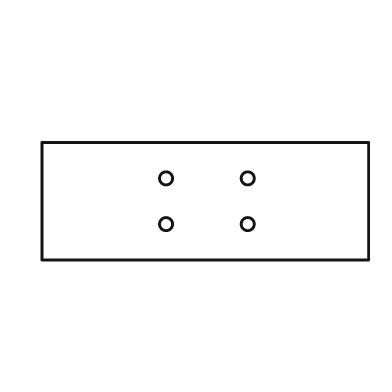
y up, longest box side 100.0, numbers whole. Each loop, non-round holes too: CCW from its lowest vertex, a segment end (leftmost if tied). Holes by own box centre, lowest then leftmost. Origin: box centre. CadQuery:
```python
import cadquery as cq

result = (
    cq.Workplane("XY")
    .moveTo(-50.0, -18.0)
    .lineTo(50.0, -18.0)
    .lineTo(50.0, 18.0)
    .lineTo(-50.0, 18.0)
    .close()
    .moveTo(-12.0, -7.0)
    .circle(2.0)
    .moveTo(13.0, -7.0)
    .circle(2.0)
    .moveTo(-12.0, 7.0)
    .circle(2.0)
    .moveTo(13.0, 7.0)
    .circle(2.0)
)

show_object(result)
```